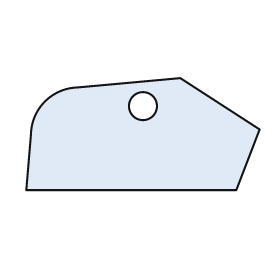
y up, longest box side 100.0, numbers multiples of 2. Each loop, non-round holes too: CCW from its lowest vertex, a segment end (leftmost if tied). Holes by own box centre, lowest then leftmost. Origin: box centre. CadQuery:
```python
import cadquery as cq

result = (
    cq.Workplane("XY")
    .moveTo(-50.0, -24.0)
    .lineTo(40.0, -24.0)
    .lineTo(50.0, 2.0)
    .lineTo(16.0, 24.0)
    .lineTo(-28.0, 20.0)
    .threePointArc((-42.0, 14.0), (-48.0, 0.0))
    .close()
    .moveTo(0.0, 12.0)
    .circle(6.0)
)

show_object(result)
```